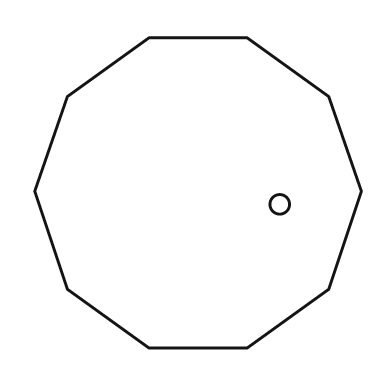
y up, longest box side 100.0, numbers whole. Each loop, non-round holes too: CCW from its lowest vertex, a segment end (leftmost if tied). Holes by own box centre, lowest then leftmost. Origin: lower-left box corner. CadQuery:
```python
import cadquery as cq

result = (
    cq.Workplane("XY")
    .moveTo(35.0, 0.0)
    .lineTo(65.0, 0.0)
    .lineTo(90.0, 18.0)
    .lineTo(100.0, 48.0)
    .lineTo(90.0, 77.0)
    .lineTo(65.0, 95.0)
    .lineTo(35.0, 95.0)
    .lineTo(10.0, 77.0)
    .lineTo(0.0, 48.0)
    .lineTo(10.0, 18.0)
    .close()
    .moveTo(75.0, 44.0)
    .circle(3.0)
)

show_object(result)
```